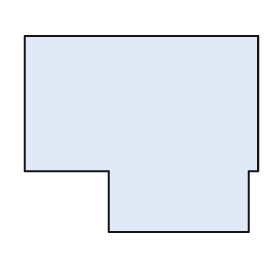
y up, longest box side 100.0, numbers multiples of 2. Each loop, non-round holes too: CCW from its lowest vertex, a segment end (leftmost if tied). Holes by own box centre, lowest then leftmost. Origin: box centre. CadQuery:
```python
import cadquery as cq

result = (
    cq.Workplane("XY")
    .moveTo(-14.0, -42.0)
    .lineTo(46.0, -42.0)
    .lineTo(46.0, -16.0)
    .lineTo(50.0, -16.0)
    .lineTo(50.0, 42.0)
    .lineTo(-50.0, 42.0)
    .lineTo(-50.0, -16.0)
    .lineTo(-14.0, -16.0)
    .close()
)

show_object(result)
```